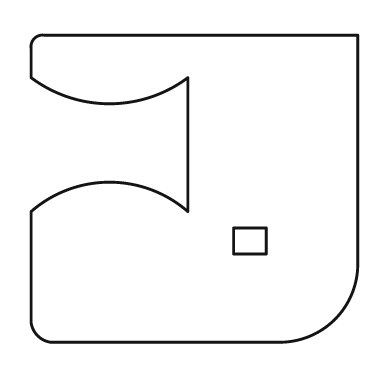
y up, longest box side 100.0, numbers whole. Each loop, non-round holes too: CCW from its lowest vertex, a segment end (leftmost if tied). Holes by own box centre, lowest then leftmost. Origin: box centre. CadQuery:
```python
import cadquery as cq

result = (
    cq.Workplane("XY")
    .moveTo(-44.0, -47.0)
    .lineTo(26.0, -47.0)
    .threePointArc((43.0, -40.0), (50.0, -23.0))
    .lineTo(50.0, 47.0)
    .lineTo(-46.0, 47.0)
    .threePointArc((-49.0, 46.0), (-50.0, 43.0))
    .lineTo(-50.0, 34.0)
    .threePointArc((-26.0, 26.0), (-2.0, 34.0))
    .lineTo(-2.0, -7.0)
    .threePointArc((-26.0, 2.0), (-50.0, -7.0))
    .lineTo(-50.0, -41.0)
    .threePointArc((-48.0, -45.0), (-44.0, -47.0))
    .close()
    .moveTo(12.0, -20.0)
    .lineTo(22.0, -20.0)
    .lineTo(22.0, -12.0)
    .lineTo(12.0, -12.0)
    .close()
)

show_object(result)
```